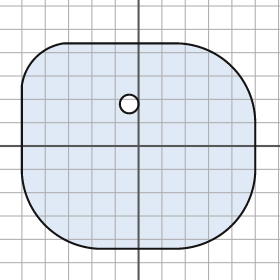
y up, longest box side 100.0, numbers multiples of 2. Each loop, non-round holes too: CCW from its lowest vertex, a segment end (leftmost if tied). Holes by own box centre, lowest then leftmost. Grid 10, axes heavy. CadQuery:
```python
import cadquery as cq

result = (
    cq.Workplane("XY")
    .moveTo(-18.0, -44.0)
    .lineTo(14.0, -44.0)
    .threePointArc((40.0, -34.0), (50.0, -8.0))
    .lineTo(50.0, 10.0)
    .threePointArc((40.0, 34.0), (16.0, 44.0))
    .lineTo(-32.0, 44.0)
    .threePointArc((-44.0, 38.0), (-50.0, 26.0))
    .lineTo(-50.0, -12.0)
    .threePointArc((-40.0, -34.0), (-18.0, -44.0))
    .close()
    .moveTo(-4.0, 18.0)
    .circle(4.0)
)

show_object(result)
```